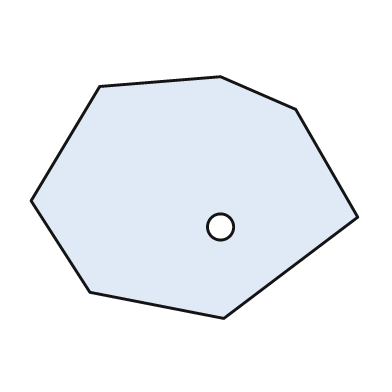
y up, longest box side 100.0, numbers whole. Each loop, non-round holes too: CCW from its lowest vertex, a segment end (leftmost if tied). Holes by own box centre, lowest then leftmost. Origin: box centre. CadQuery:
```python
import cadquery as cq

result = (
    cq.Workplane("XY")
    .moveTo(9.0, -37.0)
    .lineTo(50.0, -6.0)
    .lineTo(31.0, 27.0)
    .lineTo(8.0, 37.0)
    .lineTo(-29.0, 34.0)
    .lineTo(-50.0, -1.0)
    .lineTo(-32.0, -29.0)
    .close()
    .moveTo(8.0, -9.0)
    .circle(4.0)
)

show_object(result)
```